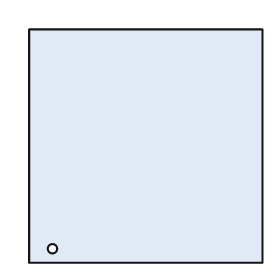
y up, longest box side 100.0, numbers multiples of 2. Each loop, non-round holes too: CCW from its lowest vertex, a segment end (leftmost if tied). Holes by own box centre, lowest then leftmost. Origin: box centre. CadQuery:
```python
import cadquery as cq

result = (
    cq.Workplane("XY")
    .moveTo(-50.0, -50.0)
    .lineTo(50.0, -50.0)
    .lineTo(50.0, 50.0)
    .lineTo(-50.0, 50.0)
    .close()
    .moveTo(-40.0, -44.0)
    .circle(2.0)
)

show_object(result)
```